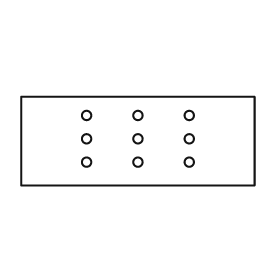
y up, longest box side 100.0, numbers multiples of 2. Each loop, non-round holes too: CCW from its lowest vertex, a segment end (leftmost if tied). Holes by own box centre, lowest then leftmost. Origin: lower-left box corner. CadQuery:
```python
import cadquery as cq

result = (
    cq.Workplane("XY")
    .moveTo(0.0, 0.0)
    .lineTo(100.0, 0.0)
    .lineTo(100.0, 38.0)
    .lineTo(0.0, 38.0)
    .close()
    .moveTo(28.0, 10.0)
    .circle(2.0)
    .moveTo(50.0, 10.0)
    .circle(2.0)
    .moveTo(72.0, 10.0)
    .circle(2.0)
    .moveTo(28.0, 20.0)
    .circle(2.0)
    .moveTo(50.0, 20.0)
    .circle(2.0)
    .moveTo(72.0, 20.0)
    .circle(2.0)
    .moveTo(28.0, 30.0)
    .circle(2.0)
    .moveTo(50.0, 30.0)
    .circle(2.0)
    .moveTo(72.0, 30.0)
    .circle(2.0)
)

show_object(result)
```